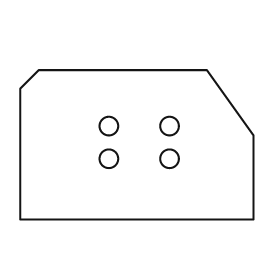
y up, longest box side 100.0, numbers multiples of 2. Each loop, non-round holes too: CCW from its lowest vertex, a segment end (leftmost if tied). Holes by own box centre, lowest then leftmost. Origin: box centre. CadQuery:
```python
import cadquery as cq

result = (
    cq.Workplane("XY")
    .moveTo(-50.0, -32.0)
    .lineTo(50.0, -32.0)
    .lineTo(50.0, 4.0)
    .lineTo(30.0, 32.0)
    .lineTo(-42.0, 32.0)
    .lineTo(-50.0, 24.0)
    .close()
    .moveTo(-12.0, -6.0)
    .circle(4.0)
    .moveTo(14.0, -6.0)
    .circle(4.0)
    .moveTo(-12.0, 8.0)
    .circle(4.0)
    .moveTo(14.0, 8.0)
    .circle(4.0)
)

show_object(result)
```